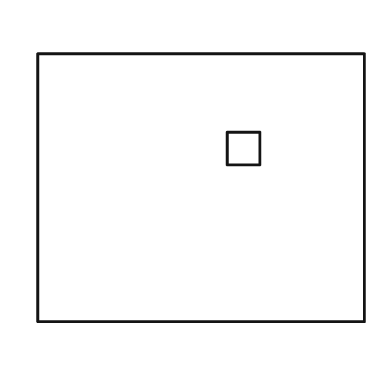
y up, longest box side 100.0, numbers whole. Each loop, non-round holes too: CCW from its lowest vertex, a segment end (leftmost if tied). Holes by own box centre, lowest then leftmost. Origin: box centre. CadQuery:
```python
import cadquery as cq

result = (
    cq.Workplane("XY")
    .moveTo(-50.0, -41.0)
    .lineTo(50.0, -41.0)
    .lineTo(50.0, 41.0)
    .lineTo(-50.0, 41.0)
    .close()
    .moveTo(8.0, 7.0)
    .lineTo(18.0, 7.0)
    .lineTo(18.0, 17.0)
    .lineTo(8.0, 17.0)
    .close()
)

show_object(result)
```